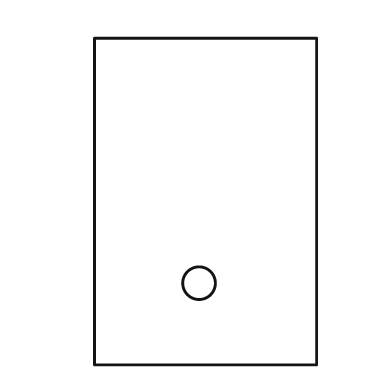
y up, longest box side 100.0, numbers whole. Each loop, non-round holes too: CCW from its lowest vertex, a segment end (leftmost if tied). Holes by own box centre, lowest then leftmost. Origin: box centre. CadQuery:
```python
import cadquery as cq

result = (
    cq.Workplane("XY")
    .moveTo(-34.0, -50.0)
    .lineTo(34.0, -50.0)
    .lineTo(34.0, 50.0)
    .lineTo(-34.0, 50.0)
    .close()
    .moveTo(-2.0, -25.0)
    .circle(5.0)
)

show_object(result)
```